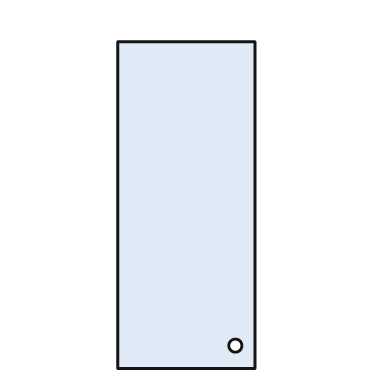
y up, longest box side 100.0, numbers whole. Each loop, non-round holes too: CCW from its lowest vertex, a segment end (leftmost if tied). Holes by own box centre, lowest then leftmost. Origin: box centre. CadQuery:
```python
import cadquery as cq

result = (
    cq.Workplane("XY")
    .moveTo(-21.0, -50.0)
    .lineTo(21.0, -50.0)
    .lineTo(21.0, 50.0)
    .lineTo(-21.0, 50.0)
    .close()
    .moveTo(15.0, -43.0)
    .circle(2.0)
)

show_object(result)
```